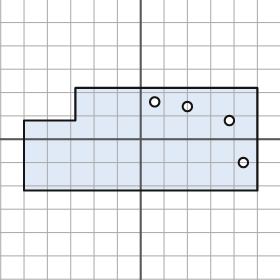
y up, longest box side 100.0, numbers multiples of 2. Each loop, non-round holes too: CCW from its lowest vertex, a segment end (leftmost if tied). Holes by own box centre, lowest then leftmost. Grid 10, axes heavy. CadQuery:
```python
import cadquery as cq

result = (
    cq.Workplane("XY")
    .moveTo(-50.0, -22.0)
    .lineTo(50.0, -22.0)
    .lineTo(50.0, 22.0)
    .lineTo(-28.0, 22.0)
    .lineTo(-28.0, 8.0)
    .lineTo(-50.0, 8.0)
    .close()
    .moveTo(44.0, -10.0)
    .circle(2.0)
    .moveTo(38.0, 8.0)
    .circle(2.0)
    .moveTo(20.0, 14.0)
    .circle(2.0)
    .moveTo(6.0, 16.0)
    .circle(2.0)
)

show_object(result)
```